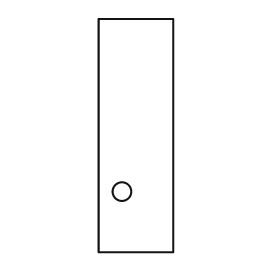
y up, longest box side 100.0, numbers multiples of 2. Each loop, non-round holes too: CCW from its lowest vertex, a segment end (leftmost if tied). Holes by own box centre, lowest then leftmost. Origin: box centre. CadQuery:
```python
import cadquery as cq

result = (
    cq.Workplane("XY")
    .moveTo(-16.0, -50.0)
    .lineTo(16.0, -50.0)
    .lineTo(16.0, 50.0)
    .lineTo(-16.0, 50.0)
    .close()
    .moveTo(-6.0, -24.0)
    .circle(4.0)
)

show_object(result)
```